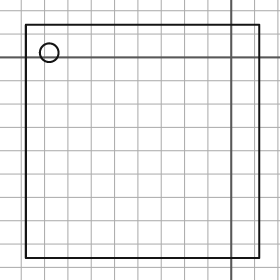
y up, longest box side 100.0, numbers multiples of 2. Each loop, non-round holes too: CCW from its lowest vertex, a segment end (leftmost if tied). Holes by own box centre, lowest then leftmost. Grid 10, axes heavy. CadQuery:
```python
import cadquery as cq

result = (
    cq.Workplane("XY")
    .moveTo(-88.0, -86.0)
    .lineTo(12.0, -86.0)
    .lineTo(12.0, 14.0)
    .lineTo(-88.0, 14.0)
    .close()
    .moveTo(-78.0, 2.0)
    .circle(4.0)
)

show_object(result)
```